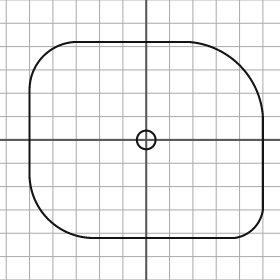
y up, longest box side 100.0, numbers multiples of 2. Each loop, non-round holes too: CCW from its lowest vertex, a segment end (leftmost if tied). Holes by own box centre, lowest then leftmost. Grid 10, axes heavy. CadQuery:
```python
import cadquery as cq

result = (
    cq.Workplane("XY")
    .moveTo(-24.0, -42.0)
    .lineTo(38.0, -42.0)
    .threePointArc((46.0, -38.0), (50.0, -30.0))
    .lineTo(50.0, 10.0)
    .threePointArc((40.0, 32.0), (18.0, 42.0))
    .lineTo(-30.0, 42.0)
    .threePointArc((-44.0, 36.0), (-50.0, 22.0))
    .lineTo(-50.0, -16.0)
    .threePointArc((-42.0, -34.0), (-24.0, -42.0))
    .close()
    .moveTo(0.0, 0.0)
    .circle(4.0)
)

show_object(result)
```